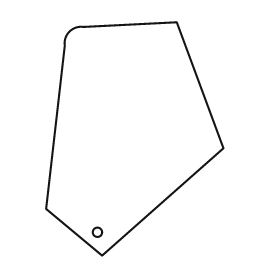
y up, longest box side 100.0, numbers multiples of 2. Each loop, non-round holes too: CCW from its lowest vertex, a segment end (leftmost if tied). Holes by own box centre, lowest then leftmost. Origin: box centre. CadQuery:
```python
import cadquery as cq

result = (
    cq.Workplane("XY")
    .moveTo(-14.0, -50.0)
    .lineTo(38.0, -4.0)
    .lineTo(18.0, 50.0)
    .lineTo(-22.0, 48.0)
    .threePointArc((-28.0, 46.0), (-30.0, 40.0))
    .lineTo(-38.0, -30.0)
    .close()
    .moveTo(-16.0, -40.0)
    .circle(2.0)
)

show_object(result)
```